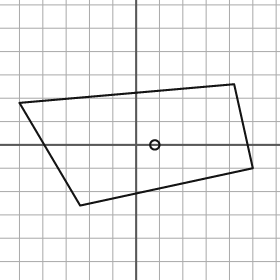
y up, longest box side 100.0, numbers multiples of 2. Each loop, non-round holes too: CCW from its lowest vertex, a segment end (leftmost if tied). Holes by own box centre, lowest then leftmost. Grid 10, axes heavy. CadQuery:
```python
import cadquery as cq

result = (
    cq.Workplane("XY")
    .moveTo(-24.0, -26.0)
    .lineTo(50.0, -10.0)
    .lineTo(42.0, 26.0)
    .lineTo(-50.0, 18.0)
    .close()
    .moveTo(8.0, 0.0)
    .circle(2.0)
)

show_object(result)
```